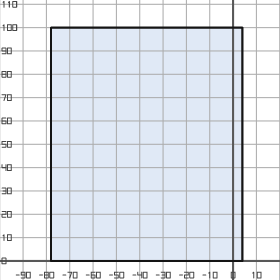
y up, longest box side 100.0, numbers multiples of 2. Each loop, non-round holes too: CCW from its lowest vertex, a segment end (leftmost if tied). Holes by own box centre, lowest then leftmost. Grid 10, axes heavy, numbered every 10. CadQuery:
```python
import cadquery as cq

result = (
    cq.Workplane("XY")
    .moveTo(-78.0, 0.0)
    .lineTo(4.0, 0.0)
    .lineTo(4.0, 100.0)
    .lineTo(-78.0, 100.0)
    .close()
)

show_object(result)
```